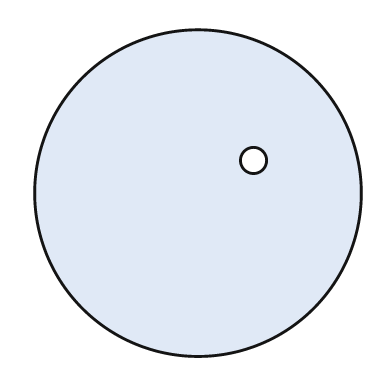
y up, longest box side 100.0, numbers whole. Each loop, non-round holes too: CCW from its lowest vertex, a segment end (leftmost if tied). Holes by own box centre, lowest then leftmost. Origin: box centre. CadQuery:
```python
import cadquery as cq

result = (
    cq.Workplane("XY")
    .moveTo(0.0, 0.0)
    .circle(50.0)
    .moveTo(17.0, 10.0)
    .circle(4.0)
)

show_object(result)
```